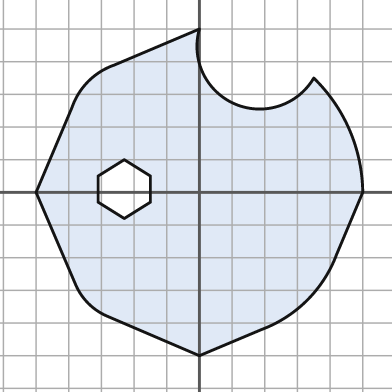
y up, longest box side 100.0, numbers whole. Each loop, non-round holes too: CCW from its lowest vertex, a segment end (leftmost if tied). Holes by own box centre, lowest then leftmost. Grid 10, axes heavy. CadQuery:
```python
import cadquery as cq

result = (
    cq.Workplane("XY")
    .moveTo(0.0, -50.0)
    .lineTo(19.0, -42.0)
    .threePointArc((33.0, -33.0), (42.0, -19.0))
    .lineTo(50.0, 0.0)
    .threePointArc((46.0, 19.0), (35.0, 35.0))
    .threePointArc((11.0, 27.0), (0.0, 50.0))
    .lineTo(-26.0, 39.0)
    .threePointArc((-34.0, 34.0), (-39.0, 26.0))
    .lineTo(-50.0, 0.0)
    .lineTo(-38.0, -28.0)
    .threePointArc((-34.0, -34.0), (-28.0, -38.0))
    .close()
    .moveTo(-23.0, -8.0)
    .lineTo(-15.0, -3.0)
    .lineTo(-15.0, 5.0)
    .lineTo(-23.0, 10.0)
    .lineTo(-31.0, 5.0)
    .lineTo(-31.0, -3.0)
    .close()
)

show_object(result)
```